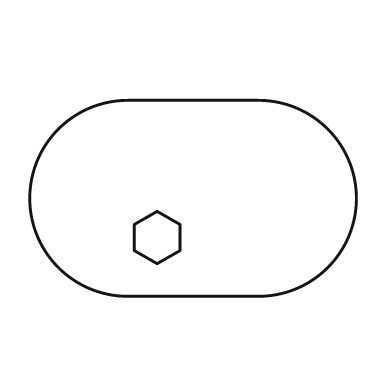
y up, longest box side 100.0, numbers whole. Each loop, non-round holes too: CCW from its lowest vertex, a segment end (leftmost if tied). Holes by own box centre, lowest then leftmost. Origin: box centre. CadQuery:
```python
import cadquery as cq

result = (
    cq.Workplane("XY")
    .moveTo(-20.0, -30.0)
    .lineTo(20.0, -30.0)
    .threePointArc((50.0, 0.0), (20.0, 30.0))
    .lineTo(-20.0, 30.0)
    .threePointArc((-50.0, 0.0), (-20.0, -30.0))
    .close()
    .moveTo(-11.0, -20.0)
    .lineTo(-4.0, -16.0)
    .lineTo(-4.0, -8.0)
    .lineTo(-11.0, -4.0)
    .lineTo(-18.0, -8.0)
    .lineTo(-18.0, -16.0)
    .close()
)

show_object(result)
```